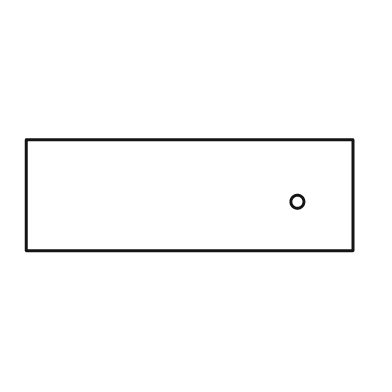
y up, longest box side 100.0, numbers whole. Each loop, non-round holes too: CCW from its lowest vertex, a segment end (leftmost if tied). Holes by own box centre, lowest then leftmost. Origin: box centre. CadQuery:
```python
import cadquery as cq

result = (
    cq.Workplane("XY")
    .moveTo(-50.0, -17.0)
    .lineTo(50.0, -17.0)
    .lineTo(50.0, 17.0)
    .lineTo(-50.0, 17.0)
    .close()
    .moveTo(33.0, -2.0)
    .circle(2.0)
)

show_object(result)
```